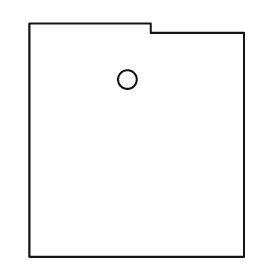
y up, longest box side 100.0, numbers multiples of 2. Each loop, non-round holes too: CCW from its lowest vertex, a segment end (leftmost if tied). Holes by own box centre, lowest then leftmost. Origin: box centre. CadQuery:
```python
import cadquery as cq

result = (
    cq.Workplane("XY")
    .moveTo(-46.0, -50.0)
    .lineTo(46.0, -50.0)
    .lineTo(46.0, 46.0)
    .lineTo(6.0, 46.0)
    .lineTo(6.0, 50.0)
    .lineTo(-46.0, 50.0)
    .close()
    .moveTo(-4.0, 26.0)
    .circle(4.0)
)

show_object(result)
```